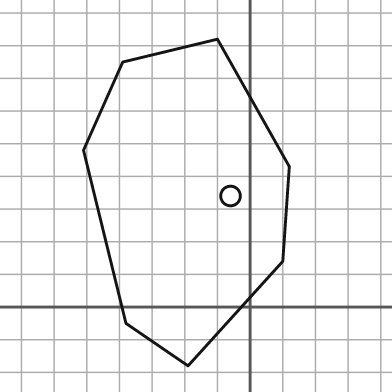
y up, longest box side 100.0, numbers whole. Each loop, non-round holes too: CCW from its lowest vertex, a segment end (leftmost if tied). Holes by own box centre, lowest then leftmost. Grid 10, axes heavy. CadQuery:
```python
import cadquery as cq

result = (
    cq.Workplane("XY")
    .moveTo(-19.0, -18.0)
    .lineTo(10.0, 14.0)
    .lineTo(12.0, 43.0)
    .lineTo(-10.0, 82.0)
    .lineTo(-39.0, 75.0)
    .lineTo(-51.0, 48.0)
    .lineTo(-38.0, -5.0)
    .close()
    .moveTo(-6.0, 34.0)
    .circle(3.0)
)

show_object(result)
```